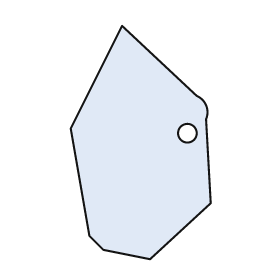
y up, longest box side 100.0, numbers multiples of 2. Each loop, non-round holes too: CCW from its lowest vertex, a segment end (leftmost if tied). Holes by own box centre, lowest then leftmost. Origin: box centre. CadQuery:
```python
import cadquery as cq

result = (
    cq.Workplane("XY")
    .moveTo(4.0, -50.0)
    .lineTo(30.0, -26.0)
    .lineTo(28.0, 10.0)
    .threePointArc((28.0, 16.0), (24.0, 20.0))
    .lineTo(-8.0, 50.0)
    .lineTo(-30.0, 6.0)
    .lineTo(-22.0, -40.0)
    .lineTo(-16.0, -46.0)
    .close()
    .moveTo(20.0, 4.0)
    .circle(4.0)
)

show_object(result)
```